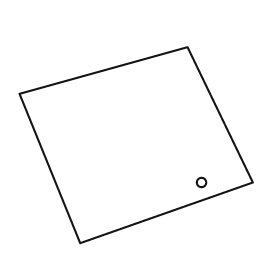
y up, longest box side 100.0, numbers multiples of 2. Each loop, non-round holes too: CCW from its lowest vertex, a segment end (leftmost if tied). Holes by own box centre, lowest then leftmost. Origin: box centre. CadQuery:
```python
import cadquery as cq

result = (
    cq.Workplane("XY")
    .moveTo(-24.0, -42.0)
    .lineTo(50.0, -16.0)
    .lineTo(22.0, 42.0)
    .lineTo(-50.0, 22.0)
    .close()
    .moveTo(28.0, -16.0)
    .circle(2.0)
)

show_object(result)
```